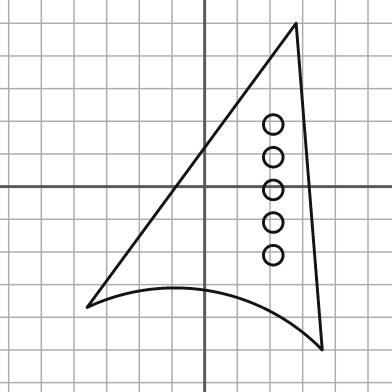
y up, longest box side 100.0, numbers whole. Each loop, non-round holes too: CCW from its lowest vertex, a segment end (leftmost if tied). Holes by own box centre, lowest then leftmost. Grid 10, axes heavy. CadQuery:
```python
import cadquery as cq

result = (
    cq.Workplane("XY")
    .moveTo(36.0, -50.0)
    .lineTo(28.0, 50.0)
    .lineTo(-36.0, -37.0)
    .threePointArc((2.0, -32.0), (36.0, -50.0))
    .close()
    .moveTo(21.0, -21.0)
    .circle(3.0)
    .moveTo(21.0, -11.0)
    .circle(3.0)
    .moveTo(21.0, -1.0)
    .circle(3.0)
    .moveTo(21.0, 9.0)
    .circle(3.0)
    .moveTo(21.0, 19.0)
    .circle(3.0)
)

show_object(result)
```